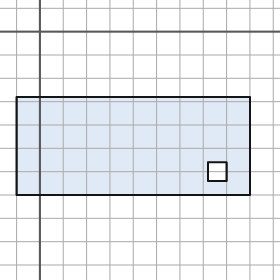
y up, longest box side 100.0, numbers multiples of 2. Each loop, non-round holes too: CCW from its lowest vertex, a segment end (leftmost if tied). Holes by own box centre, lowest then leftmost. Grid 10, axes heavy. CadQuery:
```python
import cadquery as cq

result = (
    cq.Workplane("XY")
    .moveTo(-10.0, -70.0)
    .lineTo(90.0, -70.0)
    .lineTo(90.0, -28.0)
    .lineTo(-10.0, -28.0)
    .close()
    .moveTo(72.0, -64.0)
    .lineTo(80.0, -64.0)
    .lineTo(80.0, -56.0)
    .lineTo(72.0, -56.0)
    .close()
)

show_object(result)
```